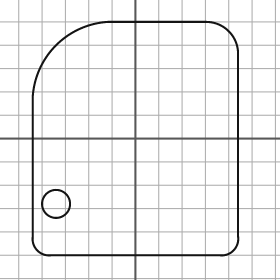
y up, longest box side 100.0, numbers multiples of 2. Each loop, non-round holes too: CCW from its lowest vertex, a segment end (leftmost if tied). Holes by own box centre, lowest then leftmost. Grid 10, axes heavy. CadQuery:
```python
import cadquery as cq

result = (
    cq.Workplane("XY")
    .moveTo(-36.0, -50.0)
    .lineTo(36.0, -50.0)
    .threePointArc((42.0, -48.0), (44.0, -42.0))
    .lineTo(44.0, 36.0)
    .threePointArc((40.0, 46.0), (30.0, 50.0))
    .lineTo(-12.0, 50.0)
    .threePointArc((-34.0, 40.0), (-44.0, 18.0))
    .lineTo(-44.0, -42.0)
    .threePointArc((-42.0, -48.0), (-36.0, -50.0))
    .close()
    .moveTo(-34.0, -28.0)
    .circle(6.0)
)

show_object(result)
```